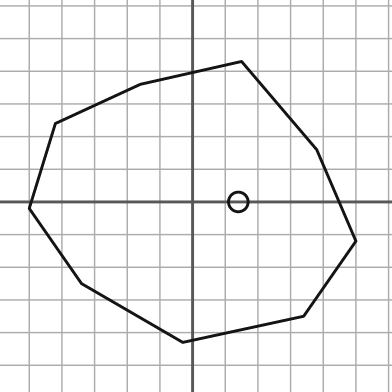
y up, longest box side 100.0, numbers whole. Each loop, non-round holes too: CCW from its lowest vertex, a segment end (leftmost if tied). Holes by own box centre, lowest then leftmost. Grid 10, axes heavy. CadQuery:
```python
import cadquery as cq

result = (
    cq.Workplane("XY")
    .moveTo(-3.0, -43.0)
    .lineTo(34.0, -35.0)
    .lineTo(50.0, -12.0)
    .lineTo(38.0, 16.0)
    .lineTo(15.0, 43.0)
    .lineTo(-16.0, 36.0)
    .lineTo(-42.0, 24.0)
    .lineTo(-50.0, -2.0)
    .lineTo(-34.0, -25.0)
    .close()
    .moveTo(14.0, 0.0)
    .circle(3.0)
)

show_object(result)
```